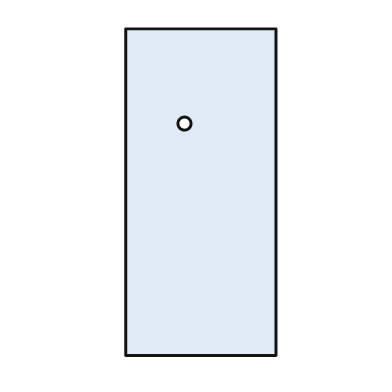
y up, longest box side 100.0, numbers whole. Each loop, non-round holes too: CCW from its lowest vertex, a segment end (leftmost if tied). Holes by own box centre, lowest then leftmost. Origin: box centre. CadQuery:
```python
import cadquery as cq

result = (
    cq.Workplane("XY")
    .moveTo(-23.0, -50.0)
    .lineTo(23.0, -50.0)
    .lineTo(23.0, 50.0)
    .lineTo(-23.0, 50.0)
    .close()
    .moveTo(-5.0, 21.0)
    .circle(2.0)
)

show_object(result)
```